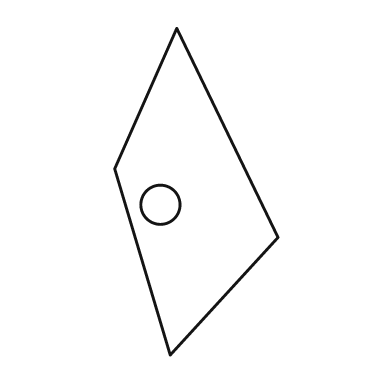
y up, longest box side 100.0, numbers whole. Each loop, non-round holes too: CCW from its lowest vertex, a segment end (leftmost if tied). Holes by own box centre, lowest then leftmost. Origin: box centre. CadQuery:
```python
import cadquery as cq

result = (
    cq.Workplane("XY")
    .moveTo(-8.0, -50.0)
    .lineTo(25.0, -14.0)
    .lineTo(-6.0, 50.0)
    .lineTo(-25.0, 7.0)
    .close()
    .moveTo(-11.0, -4.0)
    .circle(6.0)
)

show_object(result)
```